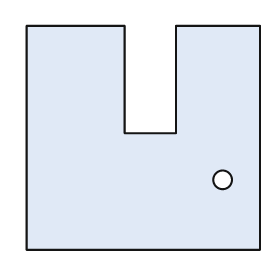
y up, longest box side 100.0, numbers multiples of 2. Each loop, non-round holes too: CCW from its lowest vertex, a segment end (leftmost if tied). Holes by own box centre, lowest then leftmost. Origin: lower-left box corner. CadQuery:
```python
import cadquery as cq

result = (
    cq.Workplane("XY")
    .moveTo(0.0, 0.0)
    .lineTo(100.0, 0.0)
    .lineTo(100.0, 96.0)
    .lineTo(64.0, 96.0)
    .lineTo(64.0, 50.0)
    .lineTo(42.0, 50.0)
    .lineTo(42.0, 96.0)
    .lineTo(0.0, 96.0)
    .close()
    .moveTo(84.0, 30.0)
    .circle(4.0)
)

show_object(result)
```